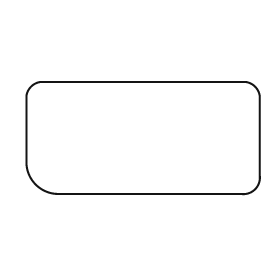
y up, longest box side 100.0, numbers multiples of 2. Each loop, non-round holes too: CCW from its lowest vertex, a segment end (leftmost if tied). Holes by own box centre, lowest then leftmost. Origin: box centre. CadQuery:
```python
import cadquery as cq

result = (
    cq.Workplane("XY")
    .moveTo(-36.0, -24.0)
    .lineTo(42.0, -24.0)
    .threePointArc((48.0, -22.0), (50.0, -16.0))
    .lineTo(50.0, 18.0)
    .threePointArc((48.0, 22.0), (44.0, 24.0))
    .lineTo(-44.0, 24.0)
    .threePointArc((-48.0, 22.0), (-50.0, 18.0))
    .lineTo(-50.0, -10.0)
    .threePointArc((-46.0, -20.0), (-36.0, -24.0))
    .close()
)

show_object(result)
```